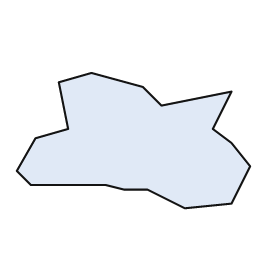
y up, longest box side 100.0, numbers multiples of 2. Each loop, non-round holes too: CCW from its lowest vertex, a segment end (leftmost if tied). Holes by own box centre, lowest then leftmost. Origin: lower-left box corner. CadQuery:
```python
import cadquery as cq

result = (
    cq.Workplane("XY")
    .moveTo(72.0, 0.0)
    .lineTo(92.0, 2.0)
    .lineTo(100.0, 18.0)
    .lineTo(92.0, 28.0)
    .lineTo(84.0, 34.0)
    .lineTo(92.0, 50.0)
    .lineTo(62.0, 44.0)
    .lineTo(54.0, 52.0)
    .lineTo(32.0, 58.0)
    .lineTo(18.0, 54.0)
    .lineTo(22.0, 34.0)
    .lineTo(8.0, 30.0)
    .lineTo(0.0, 16.0)
    .lineTo(6.0, 10.0)
    .lineTo(38.0, 10.0)
    .lineTo(46.0, 8.0)
    .lineTo(56.0, 8.0)
    .close()
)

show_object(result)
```